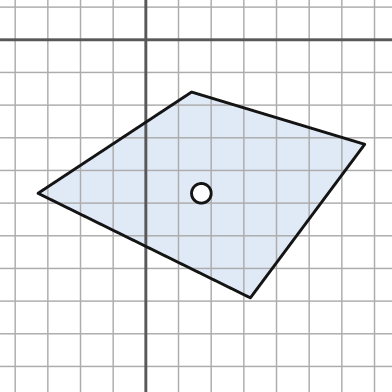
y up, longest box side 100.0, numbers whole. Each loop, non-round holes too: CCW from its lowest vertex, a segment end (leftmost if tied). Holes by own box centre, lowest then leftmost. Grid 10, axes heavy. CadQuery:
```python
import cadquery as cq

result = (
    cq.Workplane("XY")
    .moveTo(32.0, -79.0)
    .lineTo(67.0, -32.0)
    .lineTo(14.0, -16.0)
    .lineTo(-33.0, -47.0)
    .close()
    .moveTo(17.0, -47.0)
    .circle(3.0)
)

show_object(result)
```